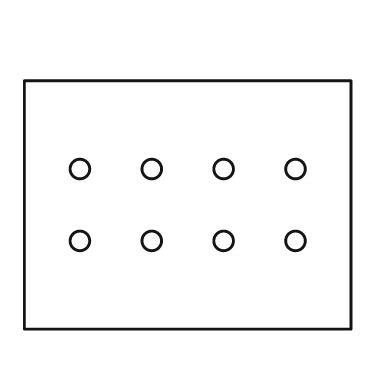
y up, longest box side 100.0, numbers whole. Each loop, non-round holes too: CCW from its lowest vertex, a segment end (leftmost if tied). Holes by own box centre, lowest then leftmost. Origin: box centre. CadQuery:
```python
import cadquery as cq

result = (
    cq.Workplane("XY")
    .moveTo(-50.0, -38.0)
    .lineTo(50.0, -38.0)
    .lineTo(50.0, 38.0)
    .lineTo(-50.0, 38.0)
    .close()
    .moveTo(-33.0, -11.0)
    .circle(3.0)
    .moveTo(-11.0, -11.0)
    .circle(3.0)
    .moveTo(11.0, -11.0)
    .circle(3.0)
    .moveTo(33.0, -11.0)
    .circle(3.0)
    .moveTo(-33.0, 11.0)
    .circle(3.0)
    .moveTo(-11.0, 11.0)
    .circle(3.0)
    .moveTo(11.0, 11.0)
    .circle(3.0)
    .moveTo(33.0, 11.0)
    .circle(3.0)
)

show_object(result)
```